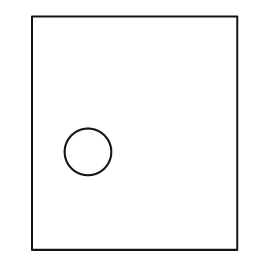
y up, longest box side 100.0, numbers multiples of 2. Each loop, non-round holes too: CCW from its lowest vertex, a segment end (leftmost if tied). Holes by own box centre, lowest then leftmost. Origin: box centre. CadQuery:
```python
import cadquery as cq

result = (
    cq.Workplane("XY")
    .moveTo(-44.0, -50.0)
    .lineTo(44.0, -50.0)
    .lineTo(44.0, 50.0)
    .lineTo(-44.0, 50.0)
    .close()
    .moveTo(-20.0, -8.0)
    .circle(10.0)
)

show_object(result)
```